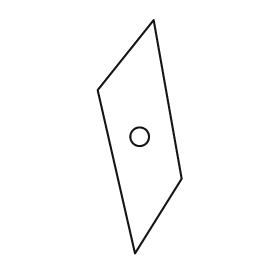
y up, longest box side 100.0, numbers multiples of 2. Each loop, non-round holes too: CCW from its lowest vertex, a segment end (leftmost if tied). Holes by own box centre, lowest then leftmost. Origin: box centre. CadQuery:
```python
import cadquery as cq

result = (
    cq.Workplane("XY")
    .moveTo(-2.0, -50.0)
    .lineTo(18.0, -18.0)
    .lineTo(6.0, 50.0)
    .lineTo(-18.0, 20.0)
    .close()
    .moveTo(0.0, 0.0)
    .circle(4.0)
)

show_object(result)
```